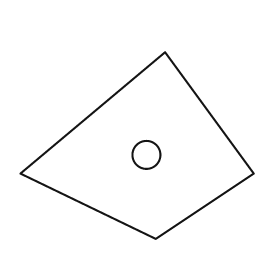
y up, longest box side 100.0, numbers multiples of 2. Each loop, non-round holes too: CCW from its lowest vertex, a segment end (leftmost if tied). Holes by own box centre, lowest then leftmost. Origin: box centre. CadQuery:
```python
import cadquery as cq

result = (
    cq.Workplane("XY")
    .moveTo(8.0, -40.0)
    .lineTo(50.0, -12.0)
    .lineTo(12.0, 40.0)
    .lineTo(-50.0, -12.0)
    .close()
    .moveTo(4.0, -4.0)
    .circle(6.0)
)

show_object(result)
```